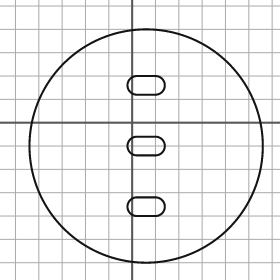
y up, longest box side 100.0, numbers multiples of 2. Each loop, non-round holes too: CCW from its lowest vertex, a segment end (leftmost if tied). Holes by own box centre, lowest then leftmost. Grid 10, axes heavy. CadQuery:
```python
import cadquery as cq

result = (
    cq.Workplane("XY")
    .moveTo(6.0, -10.0)
    .circle(50.0)
    .moveTo(2.0, -40.0)
    .lineTo(10.0, -40.0)
    .threePointArc((14.0, -36.0), (10.0, -32.0))
    .lineTo(2.0, -32.0)
    .threePointArc((-2.0, -36.0), (2.0, -40.0))
    .close()
    .moveTo(2.0, -14.0)
    .lineTo(10.0, -14.0)
    .threePointArc((14.0, -10.0), (10.0, -6.0))
    .lineTo(2.0, -6.0)
    .threePointArc((-2.0, -10.0), (2.0, -14.0))
    .close()
    .moveTo(2.0, 12.0)
    .lineTo(10.0, 12.0)
    .threePointArc((14.0, 16.0), (10.0, 20.0))
    .lineTo(2.0, 20.0)
    .threePointArc((-2.0, 16.0), (2.0, 12.0))
    .close()
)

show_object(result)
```